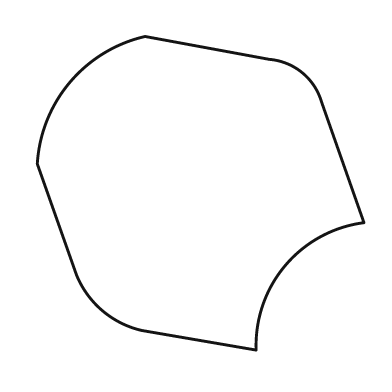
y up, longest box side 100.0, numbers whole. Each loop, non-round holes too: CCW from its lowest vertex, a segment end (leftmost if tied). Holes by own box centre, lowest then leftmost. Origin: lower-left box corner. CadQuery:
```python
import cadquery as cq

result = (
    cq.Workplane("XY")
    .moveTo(67.0, 0.0)
    .threePointArc((76.0, 26.0), (100.0, 39.0))
    .lineTo(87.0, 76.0)
    .threePointArc((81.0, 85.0), (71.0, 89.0))
    .lineTo(33.0, 96.0)
    .threePointArc((10.0, 82.0), (0.0, 57.0))
    .lineTo(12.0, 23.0)
    .threePointArc((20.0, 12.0), (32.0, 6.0))
    .close()
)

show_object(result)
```